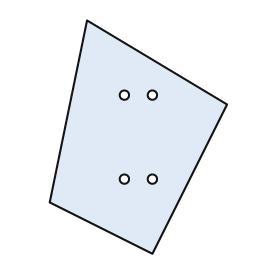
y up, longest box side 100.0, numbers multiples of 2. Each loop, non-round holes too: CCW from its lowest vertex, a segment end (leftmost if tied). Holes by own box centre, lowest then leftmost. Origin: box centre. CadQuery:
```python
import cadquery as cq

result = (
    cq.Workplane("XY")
    .moveTo(6.0, -50.0)
    .lineTo(38.0, 14.0)
    .lineTo(-22.0, 50.0)
    .lineTo(-38.0, -28.0)
    .close()
    .moveTo(-6.0, -18.0)
    .circle(2.0)
    .moveTo(6.0, -18.0)
    .circle(2.0)
    .moveTo(-6.0, 18.0)
    .circle(2.0)
    .moveTo(6.0, 18.0)
    .circle(2.0)
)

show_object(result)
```